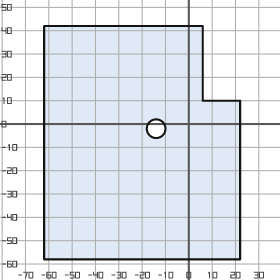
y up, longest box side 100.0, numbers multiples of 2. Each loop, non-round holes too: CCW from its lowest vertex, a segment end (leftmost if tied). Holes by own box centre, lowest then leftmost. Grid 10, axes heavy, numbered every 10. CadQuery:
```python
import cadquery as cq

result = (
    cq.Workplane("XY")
    .moveTo(-62.0, -58.0)
    .lineTo(22.0, -58.0)
    .lineTo(22.0, 10.0)
    .lineTo(6.0, 10.0)
    .lineTo(6.0, 42.0)
    .lineTo(-62.0, 42.0)
    .close()
    .moveTo(-14.0, -2.0)
    .circle(4.0)
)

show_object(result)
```